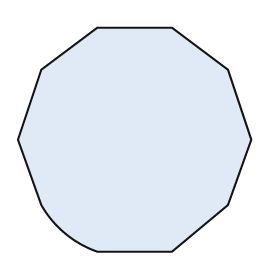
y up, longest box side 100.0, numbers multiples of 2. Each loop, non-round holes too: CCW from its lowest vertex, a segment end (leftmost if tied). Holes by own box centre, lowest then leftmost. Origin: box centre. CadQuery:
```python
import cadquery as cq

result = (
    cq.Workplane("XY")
    .moveTo(-16.0, -48.0)
    .lineTo(16.0, -48.0)
    .lineTo(40.0, -28.0)
    .lineTo(50.0, 0.0)
    .lineTo(40.0, 30.0)
    .lineTo(16.0, 48.0)
    .lineTo(-16.0, 48.0)
    .lineTo(-40.0, 30.0)
    .lineTo(-50.0, 0.0)
    .lineTo(-40.0, -28.0)
    .threePointArc((-30.0, -40.0), (-16.0, -48.0))
    .close()
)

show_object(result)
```